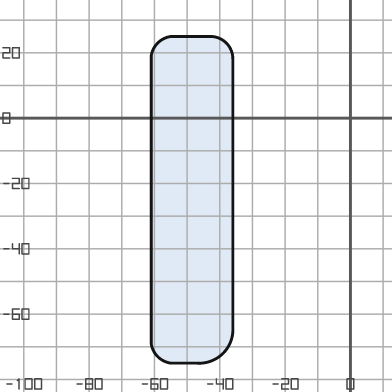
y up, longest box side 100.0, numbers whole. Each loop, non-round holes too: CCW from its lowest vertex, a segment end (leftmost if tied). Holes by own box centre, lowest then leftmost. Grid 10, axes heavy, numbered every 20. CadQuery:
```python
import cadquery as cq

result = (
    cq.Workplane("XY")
    .moveTo(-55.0, -75.0)
    .lineTo(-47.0, -75.0)
    .threePointArc((-39.0, -72.0), (-36.0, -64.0))
    .lineTo(-36.0, 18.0)
    .threePointArc((-38.0, 23.0), (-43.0, 25.0))
    .lineTo(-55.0, 25.0)
    .threePointArc((-59.0, 23.0), (-61.0, 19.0))
    .lineTo(-61.0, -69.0)
    .threePointArc((-59.0, -73.0), (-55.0, -75.0))
    .close()
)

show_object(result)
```